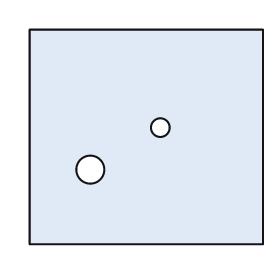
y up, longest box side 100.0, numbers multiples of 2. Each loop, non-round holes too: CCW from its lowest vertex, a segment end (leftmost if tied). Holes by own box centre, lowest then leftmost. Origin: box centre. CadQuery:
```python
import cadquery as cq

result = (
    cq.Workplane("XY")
    .moveTo(-50.0, -46.0)
    .lineTo(50.0, -46.0)
    .lineTo(50.0, 46.0)
    .lineTo(-50.0, 46.0)
    .close()
    .moveTo(-24.0, -14.0)
    .circle(6.0)
    .moveTo(6.0, 4.0)
    .circle(4.0)
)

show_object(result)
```